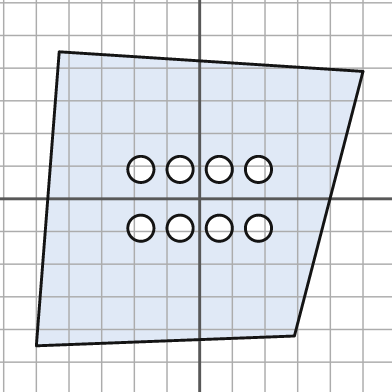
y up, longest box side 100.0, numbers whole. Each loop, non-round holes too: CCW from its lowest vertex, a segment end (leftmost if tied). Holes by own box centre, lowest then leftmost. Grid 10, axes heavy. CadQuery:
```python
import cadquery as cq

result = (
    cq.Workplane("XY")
    .moveTo(-50.0, -45.0)
    .lineTo(29.0, -42.0)
    .lineTo(50.0, 39.0)
    .lineTo(-43.0, 45.0)
    .close()
    .moveTo(-18.0, -9.0)
    .circle(4.0)
    .moveTo(-6.0, -9.0)
    .circle(4.0)
    .moveTo(6.0, -9.0)
    .circle(4.0)
    .moveTo(18.0, -9.0)
    .circle(4.0)
    .moveTo(-18.0, 9.0)
    .circle(4.0)
    .moveTo(-6.0, 9.0)
    .circle(4.0)
    .moveTo(6.0, 9.0)
    .circle(4.0)
    .moveTo(18.0, 9.0)
    .circle(4.0)
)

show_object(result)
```